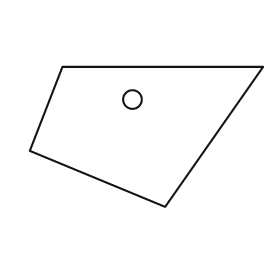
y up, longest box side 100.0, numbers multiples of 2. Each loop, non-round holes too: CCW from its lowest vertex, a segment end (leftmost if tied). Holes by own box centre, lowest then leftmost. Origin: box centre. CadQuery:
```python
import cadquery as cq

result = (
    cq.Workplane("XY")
    .moveTo(8.0, -30.0)
    .lineTo(50.0, 30.0)
    .lineTo(-36.0, 30.0)
    .lineTo(-50.0, -6.0)
    .close()
    .moveTo(-6.0, 16.0)
    .circle(4.0)
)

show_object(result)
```